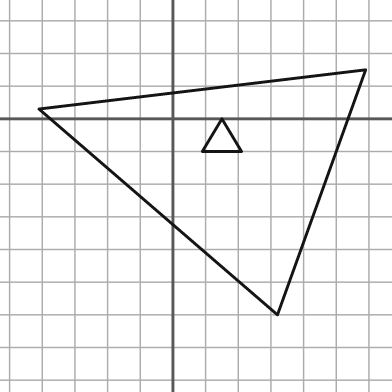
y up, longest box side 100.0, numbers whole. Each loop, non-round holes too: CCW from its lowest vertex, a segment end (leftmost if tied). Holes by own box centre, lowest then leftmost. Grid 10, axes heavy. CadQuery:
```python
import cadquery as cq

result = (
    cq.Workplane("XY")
    .moveTo(32.0, -60.0)
    .lineTo(59.0, 15.0)
    .lineTo(-41.0, 3.0)
    .close()
    .moveTo(9.0, -10.0)
    .lineTo(21.0, -10.0)
    .lineTo(15.0, 0.0)
    .close()
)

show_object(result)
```